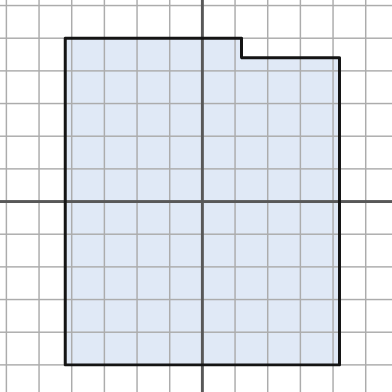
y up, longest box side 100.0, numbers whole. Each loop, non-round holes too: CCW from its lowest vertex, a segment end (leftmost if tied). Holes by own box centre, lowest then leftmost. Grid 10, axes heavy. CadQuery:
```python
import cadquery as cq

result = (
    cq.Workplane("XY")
    .moveTo(-42.0, -50.0)
    .lineTo(42.0, -50.0)
    .lineTo(42.0, 44.0)
    .lineTo(12.0, 44.0)
    .lineTo(12.0, 50.0)
    .lineTo(-42.0, 50.0)
    .close()
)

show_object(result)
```